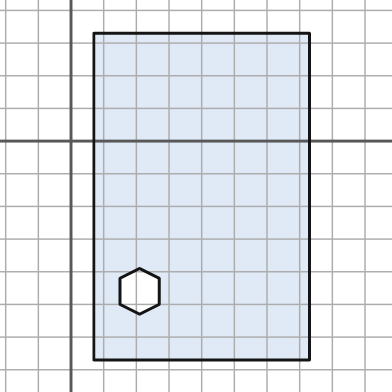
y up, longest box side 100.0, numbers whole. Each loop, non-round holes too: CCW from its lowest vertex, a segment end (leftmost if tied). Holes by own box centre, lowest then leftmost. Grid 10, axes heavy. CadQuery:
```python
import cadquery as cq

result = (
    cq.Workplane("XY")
    .moveTo(7.0, -67.0)
    .lineTo(73.0, -67.0)
    .lineTo(73.0, 33.0)
    .lineTo(7.0, 33.0)
    .close()
    .moveTo(21.0, -53.0)
    .lineTo(27.0, -50.0)
    .lineTo(27.0, -42.0)
    .lineTo(21.0, -39.0)
    .lineTo(15.0, -42.0)
    .lineTo(15.0, -50.0)
    .close()
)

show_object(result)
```